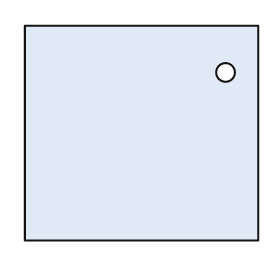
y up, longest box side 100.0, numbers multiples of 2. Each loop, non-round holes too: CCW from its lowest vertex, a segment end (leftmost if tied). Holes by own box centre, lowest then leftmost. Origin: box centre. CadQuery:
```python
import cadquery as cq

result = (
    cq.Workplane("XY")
    .moveTo(-50.0, -46.0)
    .lineTo(50.0, -46.0)
    .lineTo(50.0, 46.0)
    .lineTo(-50.0, 46.0)
    .close()
    .moveTo(36.0, 26.0)
    .circle(4.0)
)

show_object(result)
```